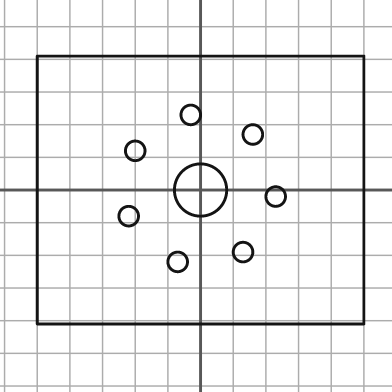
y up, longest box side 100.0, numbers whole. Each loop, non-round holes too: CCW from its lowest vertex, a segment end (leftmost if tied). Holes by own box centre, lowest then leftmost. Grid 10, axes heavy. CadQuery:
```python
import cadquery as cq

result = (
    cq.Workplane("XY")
    .moveTo(-50.0, -41.0)
    .lineTo(50.0, -41.0)
    .lineTo(50.0, 41.0)
    .lineTo(-50.0, 41.0)
    .close()
    .moveTo(-7.0, -22.0)
    .circle(3.0)
    .moveTo(13.0, -19.0)
    .circle(3.0)
    .moveTo(-22.0, -8.0)
    .circle(3.0)
    .moveTo(23.0, -2.0)
    .circle(3.0)
    .moveTo(0.0, 0.0)
    .circle(8.0)
    .moveTo(-20.0, 12.0)
    .circle(3.0)
    .moveTo(16.0, 17.0)
    .circle(3.0)
    .moveTo(-3.0, 23.0)
    .circle(3.0)
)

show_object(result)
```